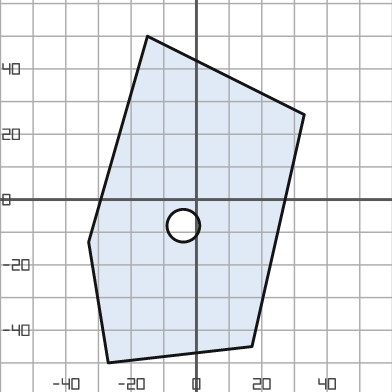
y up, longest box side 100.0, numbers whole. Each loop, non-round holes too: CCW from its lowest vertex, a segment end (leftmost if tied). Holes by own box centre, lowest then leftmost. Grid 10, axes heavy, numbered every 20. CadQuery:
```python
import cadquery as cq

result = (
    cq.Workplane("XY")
    .moveTo(-27.0, -50.0)
    .lineTo(17.0, -45.0)
    .lineTo(33.0, 26.0)
    .lineTo(-15.0, 50.0)
    .lineTo(-33.0, -13.0)
    .close()
    .moveTo(-4.0, -8.0)
    .circle(5.0)
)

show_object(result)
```